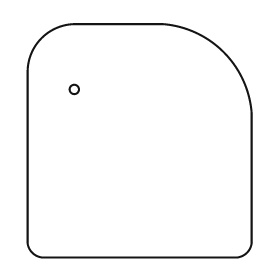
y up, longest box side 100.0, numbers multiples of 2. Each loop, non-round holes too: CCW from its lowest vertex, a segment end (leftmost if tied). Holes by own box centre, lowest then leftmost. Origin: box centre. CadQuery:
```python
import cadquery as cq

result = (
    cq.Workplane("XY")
    .moveTo(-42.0, -50.0)
    .lineTo(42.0, -50.0)
    .threePointArc((46.0, -48.0), (48.0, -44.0))
    .lineTo(48.0, 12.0)
    .threePointArc((36.0, 38.0), (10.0, 50.0))
    .lineTo(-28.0, 50.0)
    .threePointArc((-42.0, 44.0), (-48.0, 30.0))
    .lineTo(-48.0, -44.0)
    .threePointArc((-46.0, -48.0), (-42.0, -50.0))
    .close()
    .moveTo(-28.0, 22.0)
    .circle(2.0)
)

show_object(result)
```